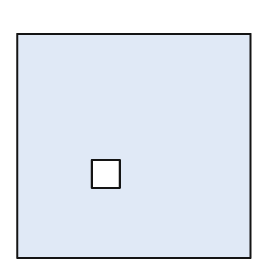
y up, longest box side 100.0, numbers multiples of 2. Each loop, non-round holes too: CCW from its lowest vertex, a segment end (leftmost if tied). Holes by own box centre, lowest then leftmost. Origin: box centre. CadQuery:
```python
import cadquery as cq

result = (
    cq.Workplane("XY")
    .moveTo(-50.0, -48.0)
    .lineTo(50.0, -48.0)
    .lineTo(50.0, 48.0)
    .lineTo(-50.0, 48.0)
    .close()
    .moveTo(-18.0, -18.0)
    .lineTo(-6.0, -18.0)
    .lineTo(-6.0, -6.0)
    .lineTo(-18.0, -6.0)
    .close()
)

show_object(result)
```